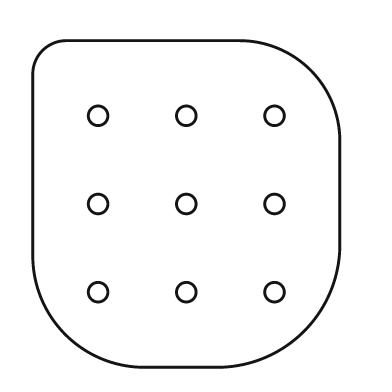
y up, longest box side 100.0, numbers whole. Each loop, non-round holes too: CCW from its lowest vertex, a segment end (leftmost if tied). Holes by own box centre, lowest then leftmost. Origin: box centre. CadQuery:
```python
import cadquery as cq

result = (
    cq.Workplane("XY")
    .moveTo(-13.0, -50.0)
    .lineTo(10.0, -50.0)
    .threePointArc((36.0, -39.0), (47.0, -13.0))
    .lineTo(47.0, 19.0)
    .threePointArc((38.0, 41.0), (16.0, 50.0))
    .lineTo(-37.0, 50.0)
    .threePointArc((-44.0, 47.0), (-47.0, 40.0))
    .lineTo(-47.0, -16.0)
    .threePointArc((-37.0, -40.0), (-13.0, -50.0))
    .close()
    .moveTo(-27.0, -27.0)
    .circle(3.0)
    .moveTo(0.0, -27.0)
    .circle(3.0)
    .moveTo(27.0, -27.0)
    .circle(3.0)
    .moveTo(-27.0, 0.0)
    .circle(3.0)
    .moveTo(0.0, 0.0)
    .circle(3.0)
    .moveTo(27.0, 0.0)
    .circle(3.0)
    .moveTo(-27.0, 27.0)
    .circle(3.0)
    .moveTo(0.0, 27.0)
    .circle(3.0)
    .moveTo(27.0, 27.0)
    .circle(3.0)
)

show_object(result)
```